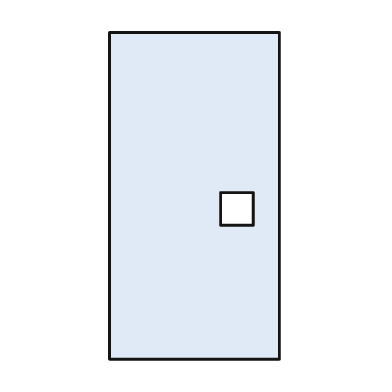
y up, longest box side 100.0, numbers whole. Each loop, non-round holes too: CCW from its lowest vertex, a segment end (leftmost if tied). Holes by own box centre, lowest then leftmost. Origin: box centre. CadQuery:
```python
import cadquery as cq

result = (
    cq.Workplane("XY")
    .moveTo(-26.0, -50.0)
    .lineTo(26.0, -50.0)
    .lineTo(26.0, 50.0)
    .lineTo(-26.0, 50.0)
    .close()
    .moveTo(8.0, -9.0)
    .lineTo(18.0, -9.0)
    .lineTo(18.0, 1.0)
    .lineTo(8.0, 1.0)
    .close()
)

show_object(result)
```